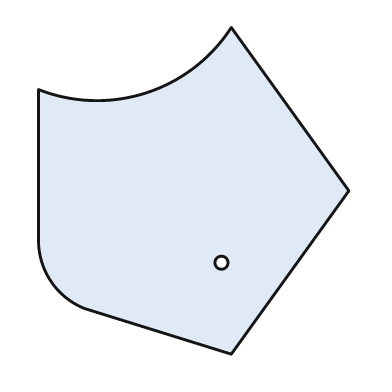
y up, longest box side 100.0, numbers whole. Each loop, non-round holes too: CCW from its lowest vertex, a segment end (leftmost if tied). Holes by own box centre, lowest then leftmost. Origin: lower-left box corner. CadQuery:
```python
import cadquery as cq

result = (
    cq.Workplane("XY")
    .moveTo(59.0, 0.0)
    .lineTo(95.0, 50.0)
    .lineTo(59.0, 100.0)
    .threePointArc((33.0, 80.0), (0.0, 81.0))
    .lineTo(0.0, 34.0)
    .threePointArc((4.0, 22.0), (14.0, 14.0))
    .close()
    .moveTo(56.0, 28.0)
    .circle(2.0)
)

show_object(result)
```